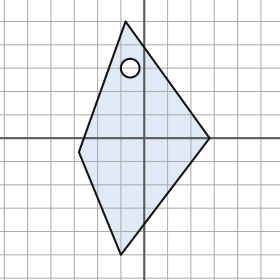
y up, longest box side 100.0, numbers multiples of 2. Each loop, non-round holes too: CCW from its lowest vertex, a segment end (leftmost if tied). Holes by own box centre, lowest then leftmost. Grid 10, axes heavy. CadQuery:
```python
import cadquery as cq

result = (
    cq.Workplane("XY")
    .moveTo(-10.0, -50.0)
    .lineTo(28.0, 0.0)
    .lineTo(-8.0, 50.0)
    .lineTo(-28.0, -6.0)
    .close()
    .moveTo(-6.0, 30.0)
    .circle(4.0)
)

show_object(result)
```